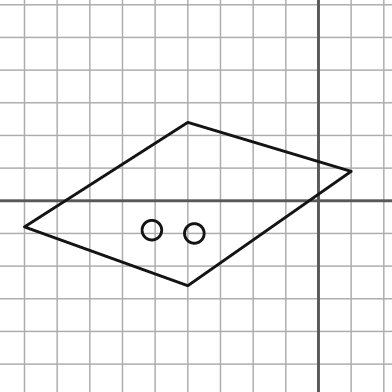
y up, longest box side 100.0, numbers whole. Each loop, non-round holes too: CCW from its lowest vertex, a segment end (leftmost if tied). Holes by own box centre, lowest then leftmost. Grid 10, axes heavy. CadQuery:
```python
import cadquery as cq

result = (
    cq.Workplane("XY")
    .moveTo(-40.0, -26.0)
    .lineTo(10.0, 9.0)
    .lineTo(-40.0, 24.0)
    .lineTo(-90.0, -8.0)
    .close()
    .moveTo(-38.0, -10.0)
    .circle(3.0)
    .moveTo(-51.0, -9.0)
    .circle(3.0)
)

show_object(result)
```